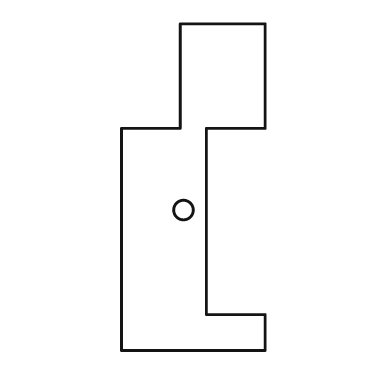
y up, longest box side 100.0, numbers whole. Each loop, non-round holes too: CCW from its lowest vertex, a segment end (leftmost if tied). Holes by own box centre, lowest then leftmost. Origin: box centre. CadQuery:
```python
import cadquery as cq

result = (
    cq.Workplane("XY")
    .moveTo(-22.0, -50.0)
    .lineTo(22.0, -50.0)
    .lineTo(22.0, -39.0)
    .lineTo(4.0, -39.0)
    .lineTo(4.0, 18.0)
    .lineTo(22.0, 18.0)
    .lineTo(22.0, 50.0)
    .lineTo(-4.0, 50.0)
    .lineTo(-4.0, 18.0)
    .lineTo(-22.0, 18.0)
    .close()
    .moveTo(-3.0, -7.0)
    .circle(3.0)
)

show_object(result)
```